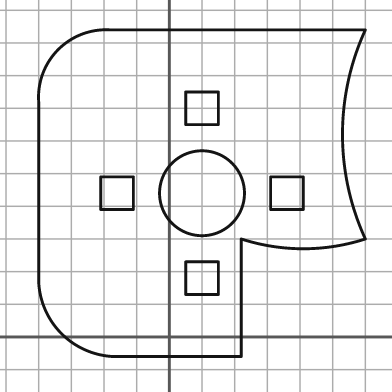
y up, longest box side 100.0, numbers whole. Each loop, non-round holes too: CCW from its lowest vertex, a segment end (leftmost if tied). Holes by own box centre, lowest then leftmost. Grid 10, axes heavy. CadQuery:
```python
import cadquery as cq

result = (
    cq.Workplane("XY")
    .moveTo(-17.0, -6.0)
    .lineTo(22.0, -6.0)
    .lineTo(22.0, 30.0)
    .threePointArc((41.0, 27.0), (60.0, 30.0))
    .threePointArc((53.0, 62.0), (60.0, 94.0))
    .lineTo(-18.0, 94.0)
    .threePointArc((-34.0, 88.0), (-40.0, 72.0))
    .lineTo(-40.0, 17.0)
    .threePointArc((-33.0, 1.0), (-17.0, -6.0))
    .close()
    .moveTo(5.0, 13.0)
    .lineTo(15.0, 13.0)
    .lineTo(15.0, 23.0)
    .lineTo(5.0, 23.0)
    .close()
    .moveTo(-21.0, 39.0)
    .lineTo(-11.0, 39.0)
    .lineTo(-11.0, 49.0)
    .lineTo(-21.0, 49.0)
    .close()
    .moveTo(10.0, 44.0)
    .circle(13.0)
    .moveTo(31.0, 39.0)
    .lineTo(41.0, 39.0)
    .lineTo(41.0, 49.0)
    .lineTo(31.0, 49.0)
    .close()
    .moveTo(5.0, 65.0)
    .lineTo(15.0, 65.0)
    .lineTo(15.0, 75.0)
    .lineTo(5.0, 75.0)
    .close()
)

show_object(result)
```